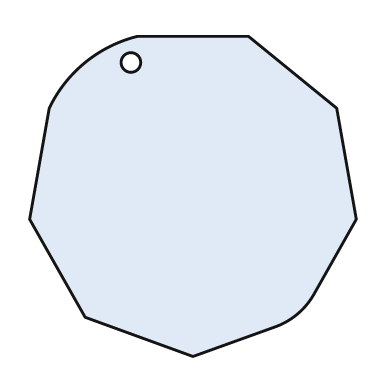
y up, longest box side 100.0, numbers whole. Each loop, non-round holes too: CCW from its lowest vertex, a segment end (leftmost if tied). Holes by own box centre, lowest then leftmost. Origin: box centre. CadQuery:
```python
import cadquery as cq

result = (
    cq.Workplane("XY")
    .moveTo(0.0, -49.0)
    .lineTo(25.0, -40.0)
    .threePointArc((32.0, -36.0), (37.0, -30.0))
    .lineTo(50.0, -7.0)
    .lineTo(44.0, 27.0)
    .lineTo(17.0, 49.0)
    .lineTo(-17.0, 49.0)
    .threePointArc((-33.0, 41.0), (-44.0, 27.0))
    .lineTo(-50.0, -7.0)
    .lineTo(-33.0, -37.0)
    .close()
    .moveTo(-19.0, 41.0)
    .circle(3.0)
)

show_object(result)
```